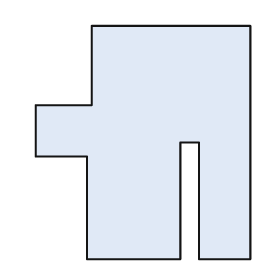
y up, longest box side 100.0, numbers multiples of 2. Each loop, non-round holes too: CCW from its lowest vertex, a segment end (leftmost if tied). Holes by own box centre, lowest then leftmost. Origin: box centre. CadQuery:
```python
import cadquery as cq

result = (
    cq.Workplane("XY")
    .moveTo(-24.0, -50.0)
    .lineTo(16.0, -50.0)
    .lineTo(16.0, 0.0)
    .lineTo(24.0, 0.0)
    .lineTo(24.0, -50.0)
    .lineTo(46.0, -50.0)
    .lineTo(46.0, 50.0)
    .lineTo(-22.0, 50.0)
    .lineTo(-22.0, 16.0)
    .lineTo(-46.0, 16.0)
    .lineTo(-46.0, -6.0)
    .lineTo(-24.0, -6.0)
    .close()
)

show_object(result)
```